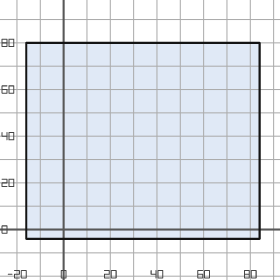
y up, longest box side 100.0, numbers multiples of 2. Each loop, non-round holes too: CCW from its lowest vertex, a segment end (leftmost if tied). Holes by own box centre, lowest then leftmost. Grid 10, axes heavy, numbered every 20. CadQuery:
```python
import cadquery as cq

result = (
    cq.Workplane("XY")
    .moveTo(-16.0, -4.0)
    .lineTo(84.0, -4.0)
    .lineTo(84.0, 80.0)
    .lineTo(-16.0, 80.0)
    .close()
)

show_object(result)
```